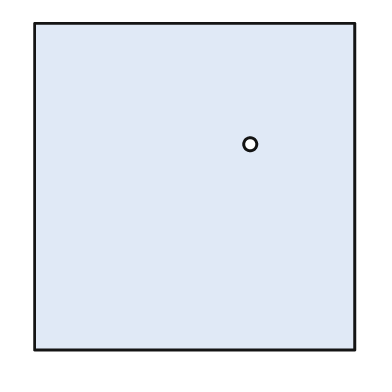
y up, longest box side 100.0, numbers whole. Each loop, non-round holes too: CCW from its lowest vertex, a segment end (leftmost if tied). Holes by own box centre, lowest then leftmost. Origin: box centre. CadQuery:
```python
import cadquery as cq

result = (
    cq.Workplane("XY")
    .moveTo(-49.0, -50.0)
    .lineTo(49.0, -50.0)
    .lineTo(49.0, 50.0)
    .lineTo(-49.0, 50.0)
    .close()
    .moveTo(17.0, 13.0)
    .circle(2.0)
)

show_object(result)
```